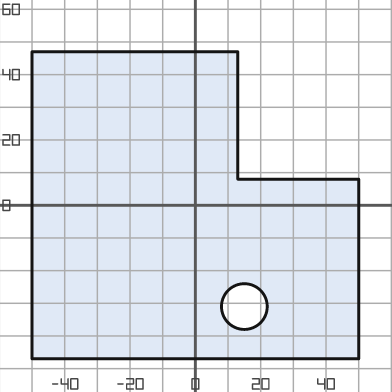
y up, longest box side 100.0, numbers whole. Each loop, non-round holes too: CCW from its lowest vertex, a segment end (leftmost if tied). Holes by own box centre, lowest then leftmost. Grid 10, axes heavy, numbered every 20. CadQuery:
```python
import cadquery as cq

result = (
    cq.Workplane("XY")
    .moveTo(-50.0, -47.0)
    .lineTo(50.0, -47.0)
    .lineTo(50.0, 8.0)
    .lineTo(13.0, 8.0)
    .lineTo(13.0, 47.0)
    .lineTo(-50.0, 47.0)
    .close()
    .moveTo(15.0, -31.0)
    .circle(7.0)
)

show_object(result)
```